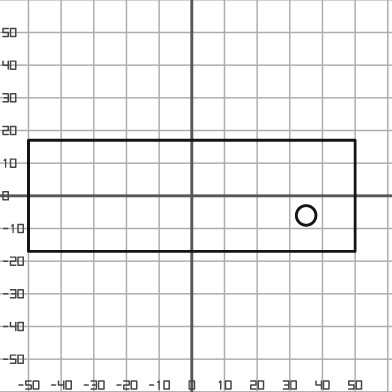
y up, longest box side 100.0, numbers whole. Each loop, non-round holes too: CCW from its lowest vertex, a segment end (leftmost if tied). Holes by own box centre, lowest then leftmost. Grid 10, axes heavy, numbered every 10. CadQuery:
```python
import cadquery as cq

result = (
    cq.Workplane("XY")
    .moveTo(-50.0, -17.0)
    .lineTo(50.0, -17.0)
    .lineTo(50.0, 17.0)
    .lineTo(-50.0, 17.0)
    .close()
    .moveTo(35.0, -6.0)
    .circle(3.0)
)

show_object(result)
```